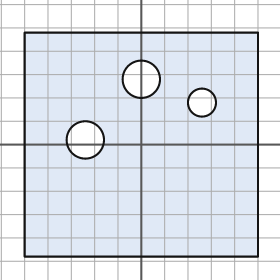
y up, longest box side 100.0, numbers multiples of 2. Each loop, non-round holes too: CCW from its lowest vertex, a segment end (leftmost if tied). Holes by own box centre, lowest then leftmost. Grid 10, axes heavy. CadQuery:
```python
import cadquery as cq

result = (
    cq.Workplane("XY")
    .moveTo(-50.0, -48.0)
    .lineTo(50.0, -48.0)
    .lineTo(50.0, 48.0)
    .lineTo(-50.0, 48.0)
    .close()
    .moveTo(-24.0, 2.0)
    .circle(8.0)
    .moveTo(26.0, 18.0)
    .circle(6.0)
    .moveTo(0.0, 28.0)
    .circle(8.0)
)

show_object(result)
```